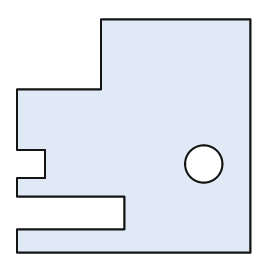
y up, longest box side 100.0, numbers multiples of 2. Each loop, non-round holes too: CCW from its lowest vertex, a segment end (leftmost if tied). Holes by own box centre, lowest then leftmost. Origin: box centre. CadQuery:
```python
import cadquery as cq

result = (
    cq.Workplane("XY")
    .moveTo(-50.0, -50.0)
    .lineTo(50.0, -50.0)
    .lineTo(50.0, 50.0)
    .lineTo(-14.0, 50.0)
    .lineTo(-14.0, 20.0)
    .lineTo(-50.0, 20.0)
    .lineTo(-50.0, -6.0)
    .lineTo(-38.0, -6.0)
    .lineTo(-38.0, -18.0)
    .lineTo(-50.0, -18.0)
    .lineTo(-50.0, -26.0)
    .lineTo(-4.0, -26.0)
    .lineTo(-4.0, -40.0)
    .lineTo(-50.0, -40.0)
    .close()
    .moveTo(30.0, -12.0)
    .circle(8.0)
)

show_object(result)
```